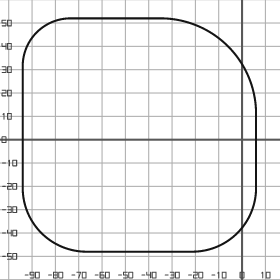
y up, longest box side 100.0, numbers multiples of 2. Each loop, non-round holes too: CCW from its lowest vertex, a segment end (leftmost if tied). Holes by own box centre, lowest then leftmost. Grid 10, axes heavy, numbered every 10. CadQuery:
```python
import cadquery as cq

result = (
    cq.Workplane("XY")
    .moveTo(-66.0, -48.0)
    .lineTo(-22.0, -48.0)
    .threePointArc((-2.0, -40.0), (6.0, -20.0))
    .lineTo(6.0, 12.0)
    .threePointArc((-6.0, 40.0), (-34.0, 52.0))
    .lineTo(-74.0, 52.0)
    .threePointArc((-88.0, 46.0), (-94.0, 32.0))
    .lineTo(-94.0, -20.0)
    .threePointArc((-86.0, -40.0), (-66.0, -48.0))
    .close()
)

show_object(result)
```